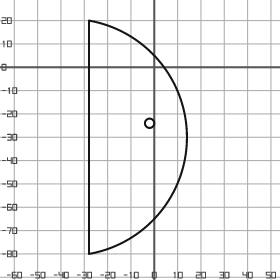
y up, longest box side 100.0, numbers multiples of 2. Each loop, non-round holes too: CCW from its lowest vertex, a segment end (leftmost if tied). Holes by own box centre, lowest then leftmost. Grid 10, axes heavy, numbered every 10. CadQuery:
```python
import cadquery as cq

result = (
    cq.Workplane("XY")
    .moveTo(-28.0, -80.0)
    .threePointArc((14.0, -30.0), (-28.0, 20.0))
    .close()
    .moveTo(-2.0, -24.0)
    .circle(2.0)
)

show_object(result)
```